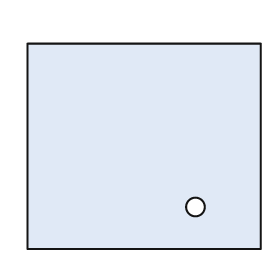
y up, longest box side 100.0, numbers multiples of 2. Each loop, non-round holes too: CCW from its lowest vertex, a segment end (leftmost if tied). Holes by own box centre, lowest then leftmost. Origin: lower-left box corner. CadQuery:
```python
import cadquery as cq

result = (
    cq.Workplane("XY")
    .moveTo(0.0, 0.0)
    .lineTo(100.0, 0.0)
    .lineTo(100.0, 88.0)
    .lineTo(0.0, 88.0)
    .close()
    .moveTo(72.0, 18.0)
    .circle(4.0)
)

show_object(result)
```